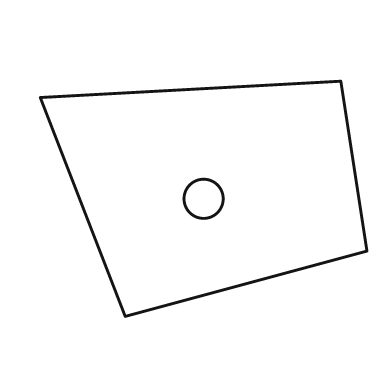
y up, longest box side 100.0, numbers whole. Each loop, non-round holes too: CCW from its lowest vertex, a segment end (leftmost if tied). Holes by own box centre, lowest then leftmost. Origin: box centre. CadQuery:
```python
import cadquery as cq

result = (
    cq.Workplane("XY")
    .moveTo(-24.0, -36.0)
    .lineTo(50.0, -16.0)
    .lineTo(42.0, 36.0)
    .lineTo(-50.0, 31.0)
    .close()
    .moveTo(0.0, 0.0)
    .circle(6.0)
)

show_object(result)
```